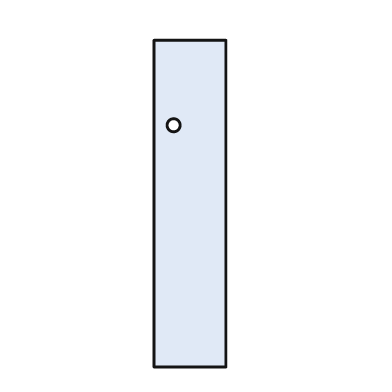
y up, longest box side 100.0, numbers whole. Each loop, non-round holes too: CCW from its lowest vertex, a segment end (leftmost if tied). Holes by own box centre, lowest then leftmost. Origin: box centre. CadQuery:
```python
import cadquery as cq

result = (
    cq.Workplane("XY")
    .moveTo(-11.0, -50.0)
    .lineTo(11.0, -50.0)
    .lineTo(11.0, 50.0)
    .lineTo(-11.0, 50.0)
    .close()
    .moveTo(-5.0, 24.0)
    .circle(2.0)
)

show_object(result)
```